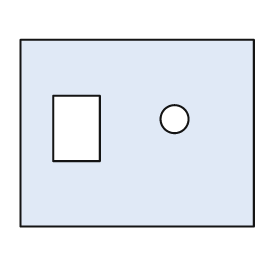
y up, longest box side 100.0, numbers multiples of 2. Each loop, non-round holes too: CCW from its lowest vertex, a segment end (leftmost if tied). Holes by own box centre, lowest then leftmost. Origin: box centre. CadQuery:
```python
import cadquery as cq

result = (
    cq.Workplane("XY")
    .moveTo(-50.0, -40.0)
    .lineTo(50.0, -40.0)
    .lineTo(50.0, 40.0)
    .lineTo(-50.0, 40.0)
    .close()
    .moveTo(-36.0, -12.0)
    .lineTo(-16.0, -12.0)
    .lineTo(-16.0, 16.0)
    .lineTo(-36.0, 16.0)
    .close()
    .moveTo(16.0, 6.0)
    .circle(6.0)
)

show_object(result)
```